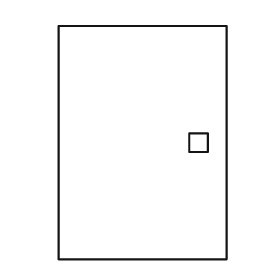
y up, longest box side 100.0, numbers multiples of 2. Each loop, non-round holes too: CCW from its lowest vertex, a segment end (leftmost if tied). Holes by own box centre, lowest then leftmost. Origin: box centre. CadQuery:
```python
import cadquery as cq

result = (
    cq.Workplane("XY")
    .moveTo(-36.0, -50.0)
    .lineTo(36.0, -50.0)
    .lineTo(36.0, 50.0)
    .lineTo(-36.0, 50.0)
    .close()
    .moveTo(20.0, -4.0)
    .lineTo(28.0, -4.0)
    .lineTo(28.0, 4.0)
    .lineTo(20.0, 4.0)
    .close()
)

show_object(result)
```